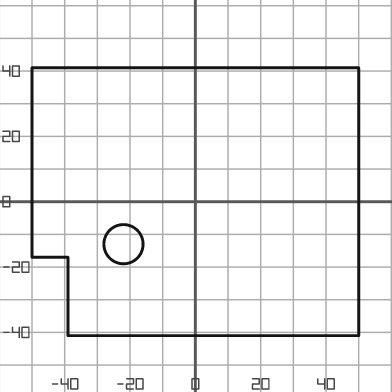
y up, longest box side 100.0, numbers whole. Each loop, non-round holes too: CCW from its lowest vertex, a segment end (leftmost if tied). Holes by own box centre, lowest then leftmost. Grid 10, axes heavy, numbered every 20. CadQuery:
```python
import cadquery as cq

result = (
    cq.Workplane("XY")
    .moveTo(-39.0, -41.0)
    .lineTo(50.0, -41.0)
    .lineTo(50.0, 41.0)
    .lineTo(-50.0, 41.0)
    .lineTo(-50.0, -17.0)
    .lineTo(-39.0, -17.0)
    .close()
    .moveTo(-22.0, -13.0)
    .circle(6.0)
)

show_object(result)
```